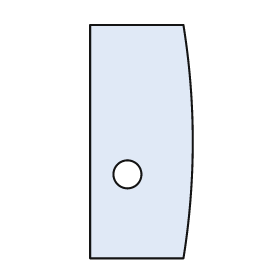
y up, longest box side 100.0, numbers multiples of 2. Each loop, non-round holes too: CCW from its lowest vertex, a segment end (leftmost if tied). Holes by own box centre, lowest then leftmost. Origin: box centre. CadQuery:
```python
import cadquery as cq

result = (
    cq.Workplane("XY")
    .moveTo(-22.0, -50.0)
    .lineTo(18.0, -50.0)
    .threePointArc((22.0, 0.0), (18.0, 50.0))
    .lineTo(-22.0, 50.0)
    .close()
    .moveTo(-6.0, -14.0)
    .circle(6.0)
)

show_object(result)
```